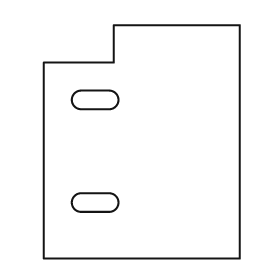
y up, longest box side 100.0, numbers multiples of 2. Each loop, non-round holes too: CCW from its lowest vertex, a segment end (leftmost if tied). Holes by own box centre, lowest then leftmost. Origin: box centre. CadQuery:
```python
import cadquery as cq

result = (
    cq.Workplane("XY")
    .moveTo(-42.0, -50.0)
    .lineTo(42.0, -50.0)
    .lineTo(42.0, 50.0)
    .lineTo(-12.0, 50.0)
    .lineTo(-12.0, 34.0)
    .lineTo(-42.0, 34.0)
    .close()
    .moveTo(-26.0, -30.0)
    .lineTo(-14.0, -30.0)
    .threePointArc((-10.0, -26.0), (-14.0, -22.0))
    .lineTo(-26.0, -22.0)
    .threePointArc((-30.0, -26.0), (-26.0, -30.0))
    .close()
    .moveTo(-26.0, 14.0)
    .lineTo(-14.0, 14.0)
    .threePointArc((-10.0, 18.0), (-14.0, 22.0))
    .lineTo(-26.0, 22.0)
    .threePointArc((-30.0, 18.0), (-26.0, 14.0))
    .close()
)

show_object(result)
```